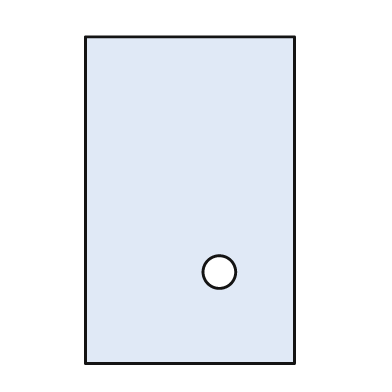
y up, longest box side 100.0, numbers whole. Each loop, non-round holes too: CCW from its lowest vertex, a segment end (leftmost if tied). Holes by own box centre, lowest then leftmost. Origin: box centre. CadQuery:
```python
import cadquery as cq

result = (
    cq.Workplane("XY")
    .moveTo(-32.0, -50.0)
    .lineTo(32.0, -50.0)
    .lineTo(32.0, 50.0)
    .lineTo(-32.0, 50.0)
    .close()
    .moveTo(9.0, -22.0)
    .circle(5.0)
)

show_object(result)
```